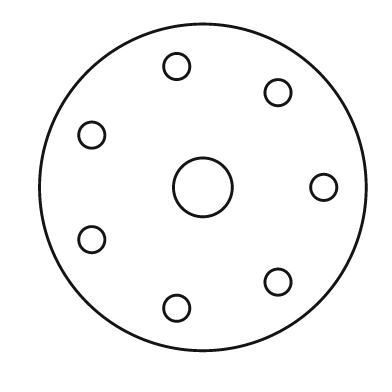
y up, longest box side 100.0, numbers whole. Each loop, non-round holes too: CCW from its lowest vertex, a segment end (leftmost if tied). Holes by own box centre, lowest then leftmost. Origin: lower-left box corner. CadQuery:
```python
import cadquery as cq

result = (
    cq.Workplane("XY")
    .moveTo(50.0, 50.0)
    .circle(50.0)
    .moveTo(42.0, 13.0)
    .circle(4.0)
    .moveTo(73.0, 21.0)
    .circle(4.0)
    .moveTo(16.0, 34.0)
    .circle(4.0)
    .moveTo(50.0, 50.0)
    .circle(9.0)
    .moveTo(87.0, 50.0)
    .circle(4.0)
    .moveTo(16.0, 66.0)
    .circle(4.0)
    .moveTo(73.0, 79.0)
    .circle(4.0)
    .moveTo(42.0, 87.0)
    .circle(4.0)
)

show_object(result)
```